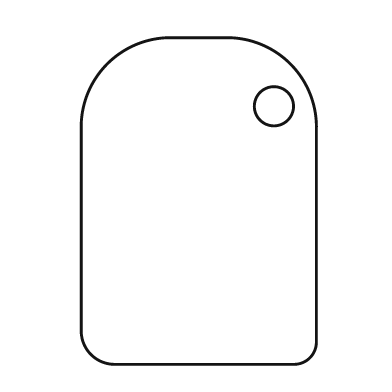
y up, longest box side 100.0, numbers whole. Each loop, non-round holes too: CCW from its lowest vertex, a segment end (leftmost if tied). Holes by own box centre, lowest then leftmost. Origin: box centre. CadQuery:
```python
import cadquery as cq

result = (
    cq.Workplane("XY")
    .moveTo(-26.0, -50.0)
    .lineTo(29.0, -50.0)
    .threePointArc((34.0, -48.0), (36.0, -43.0))
    .lineTo(36.0, 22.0)
    .threePointArc((28.0, 42.0), (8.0, 50.0))
    .lineTo(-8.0, 50.0)
    .threePointArc((-28.0, 42.0), (-36.0, 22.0))
    .lineTo(-36.0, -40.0)
    .threePointArc((-33.0, -47.0), (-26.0, -50.0))
    .close()
    .moveTo(23.0, 29.0)
    .circle(6.0)
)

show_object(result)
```